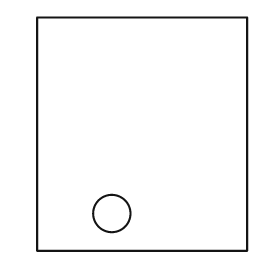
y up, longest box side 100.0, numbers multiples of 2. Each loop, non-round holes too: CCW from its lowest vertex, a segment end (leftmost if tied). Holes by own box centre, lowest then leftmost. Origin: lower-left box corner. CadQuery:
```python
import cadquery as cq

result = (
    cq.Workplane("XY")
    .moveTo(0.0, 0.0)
    .lineTo(90.0, 0.0)
    .lineTo(90.0, 100.0)
    .lineTo(0.0, 100.0)
    .close()
    .moveTo(32.0, 16.0)
    .circle(8.0)
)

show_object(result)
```